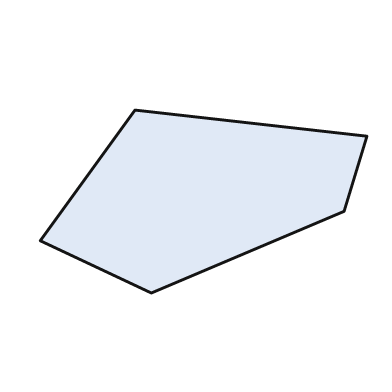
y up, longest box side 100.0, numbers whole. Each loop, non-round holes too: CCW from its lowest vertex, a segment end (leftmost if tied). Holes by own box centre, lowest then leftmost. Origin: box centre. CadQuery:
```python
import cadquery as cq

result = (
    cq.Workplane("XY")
    .moveTo(-16.0, -28.0)
    .lineTo(43.0, -3.0)
    .lineTo(50.0, 20.0)
    .lineTo(-21.0, 28.0)
    .lineTo(-50.0, -12.0)
    .close()
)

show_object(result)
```